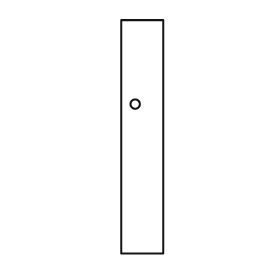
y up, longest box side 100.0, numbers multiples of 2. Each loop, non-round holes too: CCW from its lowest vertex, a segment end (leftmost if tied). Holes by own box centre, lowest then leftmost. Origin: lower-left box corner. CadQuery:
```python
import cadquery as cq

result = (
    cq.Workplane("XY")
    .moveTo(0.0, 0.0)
    .lineTo(18.0, 0.0)
    .lineTo(18.0, 100.0)
    .lineTo(0.0, 100.0)
    .close()
    .moveTo(6.0, 64.0)
    .circle(2.0)
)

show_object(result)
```